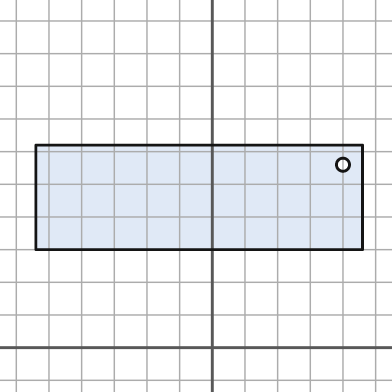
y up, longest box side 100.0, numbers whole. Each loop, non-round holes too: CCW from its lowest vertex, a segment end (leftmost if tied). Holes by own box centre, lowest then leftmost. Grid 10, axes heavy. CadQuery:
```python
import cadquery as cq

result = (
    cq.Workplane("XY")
    .moveTo(-54.0, 30.0)
    .lineTo(46.0, 30.0)
    .lineTo(46.0, 62.0)
    .lineTo(-54.0, 62.0)
    .close()
    .moveTo(40.0, 56.0)
    .circle(2.0)
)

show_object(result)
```